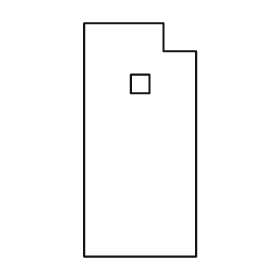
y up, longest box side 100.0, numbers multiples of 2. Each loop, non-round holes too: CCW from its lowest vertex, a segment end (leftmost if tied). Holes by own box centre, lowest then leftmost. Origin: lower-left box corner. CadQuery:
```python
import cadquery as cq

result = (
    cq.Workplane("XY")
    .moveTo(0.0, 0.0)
    .lineTo(48.0, 0.0)
    .lineTo(48.0, 88.0)
    .lineTo(34.0, 88.0)
    .lineTo(34.0, 100.0)
    .lineTo(0.0, 100.0)
    .close()
    .moveTo(20.0, 70.0)
    .lineTo(28.0, 70.0)
    .lineTo(28.0, 78.0)
    .lineTo(20.0, 78.0)
    .close()
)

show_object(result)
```